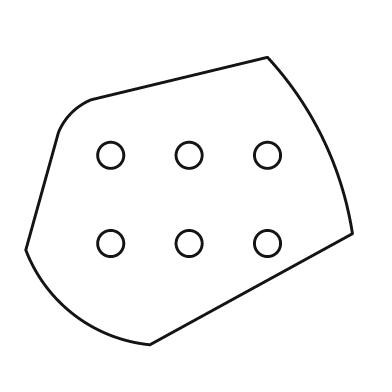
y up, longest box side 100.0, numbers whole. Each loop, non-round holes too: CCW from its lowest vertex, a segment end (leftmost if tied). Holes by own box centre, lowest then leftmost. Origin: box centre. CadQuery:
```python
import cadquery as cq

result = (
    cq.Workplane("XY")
    .moveTo(-12.0, -44.0)
    .lineTo(50.0, -10.0)
    .threePointArc((41.0, 19.0), (24.0, 44.0))
    .lineTo(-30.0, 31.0)
    .threePointArc((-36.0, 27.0), (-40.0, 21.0))
    .lineTo(-50.0, -15.0)
    .threePointArc((-35.0, -35.0), (-12.0, -44.0))
    .close()
    .moveTo(-24.0, -13.0)
    .circle(4.0)
    .moveTo(0.0, -13.0)
    .circle(4.0)
    .moveTo(24.0, -13.0)
    .circle(4.0)
    .moveTo(-24.0, 14.0)
    .circle(4.0)
    .moveTo(0.0, 14.0)
    .circle(4.0)
    .moveTo(24.0, 14.0)
    .circle(4.0)
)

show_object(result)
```